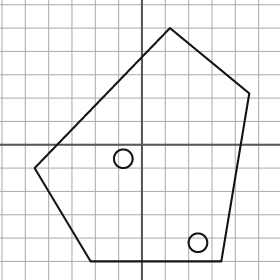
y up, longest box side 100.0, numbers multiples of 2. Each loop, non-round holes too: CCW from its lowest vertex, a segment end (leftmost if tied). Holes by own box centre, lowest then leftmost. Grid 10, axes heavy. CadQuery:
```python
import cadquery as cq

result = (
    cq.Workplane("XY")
    .moveTo(-22.0, -50.0)
    .lineTo(34.0, -50.0)
    .lineTo(46.0, 22.0)
    .lineTo(12.0, 50.0)
    .lineTo(-46.0, -10.0)
    .close()
    .moveTo(24.0, -42.0)
    .circle(4.0)
    .moveTo(-8.0, -6.0)
    .circle(4.0)
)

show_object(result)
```